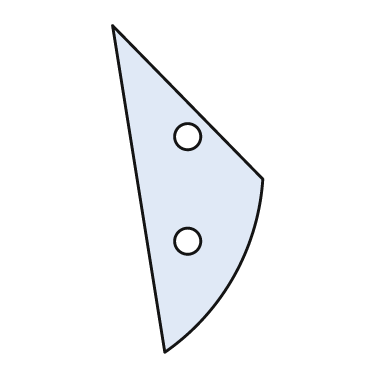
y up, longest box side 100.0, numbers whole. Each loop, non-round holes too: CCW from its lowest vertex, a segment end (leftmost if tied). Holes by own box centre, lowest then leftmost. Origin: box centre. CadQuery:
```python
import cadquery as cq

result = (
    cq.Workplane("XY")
    .moveTo(-7.0, -50.0)
    .threePointArc((14.0, -27.0), (23.0, 3.0))
    .lineTo(-23.0, 50.0)
    .close()
    .moveTo(0.0, -16.0)
    .circle(4.0)
    .moveTo(0.0, 16.0)
    .circle(4.0)
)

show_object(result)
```